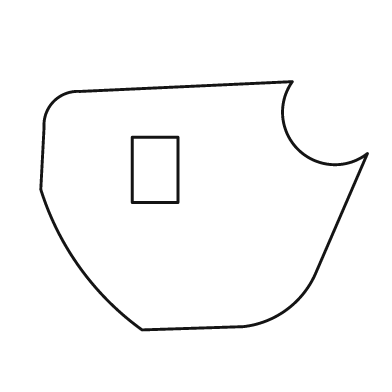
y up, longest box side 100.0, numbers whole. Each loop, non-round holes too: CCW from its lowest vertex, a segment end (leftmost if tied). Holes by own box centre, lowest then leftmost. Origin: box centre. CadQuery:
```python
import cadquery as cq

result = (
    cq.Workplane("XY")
    .moveTo(-19.0, -38.0)
    .lineTo(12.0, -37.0)
    .threePointArc((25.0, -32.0), (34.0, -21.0))
    .lineTo(50.0, 16.0)
    .threePointArc((29.0, 17.0), (27.0, 38.0))
    .lineTo(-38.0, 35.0)
    .threePointArc((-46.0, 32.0), (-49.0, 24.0))
    .lineTo(-50.0, 5.0)
    .threePointArc((-38.0, -19.0), (-19.0, -38.0))
    .close()
    .moveTo(-22.0, 1.0)
    .lineTo(-8.0, 1.0)
    .lineTo(-8.0, 21.0)
    .lineTo(-22.0, 21.0)
    .close()
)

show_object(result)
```